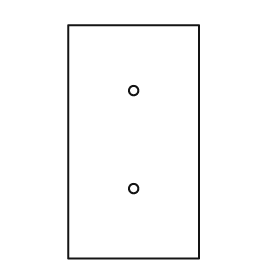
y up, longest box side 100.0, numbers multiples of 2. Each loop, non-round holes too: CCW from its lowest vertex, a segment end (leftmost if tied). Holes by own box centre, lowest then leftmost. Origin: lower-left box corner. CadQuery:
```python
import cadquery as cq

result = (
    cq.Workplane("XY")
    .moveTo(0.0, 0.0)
    .lineTo(56.0, 0.0)
    .lineTo(56.0, 100.0)
    .lineTo(0.0, 100.0)
    .close()
    .moveTo(28.0, 30.0)
    .circle(2.0)
    .moveTo(28.0, 72.0)
    .circle(2.0)
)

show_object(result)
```